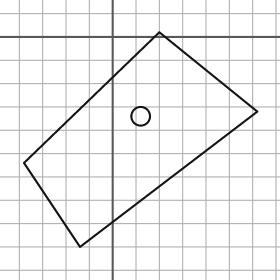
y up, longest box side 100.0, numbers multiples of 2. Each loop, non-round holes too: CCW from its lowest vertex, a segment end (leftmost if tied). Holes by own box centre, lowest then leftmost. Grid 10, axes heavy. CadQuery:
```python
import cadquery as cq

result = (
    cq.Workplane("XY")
    .moveTo(-14.0, -90.0)
    .lineTo(62.0, -32.0)
    .lineTo(20.0, 2.0)
    .lineTo(-38.0, -54.0)
    .close()
    .moveTo(12.0, -34.0)
    .circle(4.0)
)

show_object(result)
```